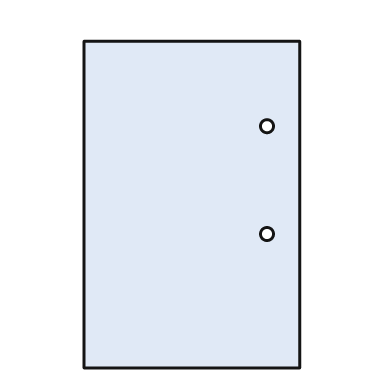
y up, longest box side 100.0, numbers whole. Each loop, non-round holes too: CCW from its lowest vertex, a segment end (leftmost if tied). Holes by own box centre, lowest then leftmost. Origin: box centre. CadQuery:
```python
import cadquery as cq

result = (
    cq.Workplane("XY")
    .moveTo(-33.0, -50.0)
    .lineTo(33.0, -50.0)
    .lineTo(33.0, 50.0)
    .lineTo(-33.0, 50.0)
    .close()
    .moveTo(23.0, -9.0)
    .circle(2.0)
    .moveTo(23.0, 24.0)
    .circle(2.0)
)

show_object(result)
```